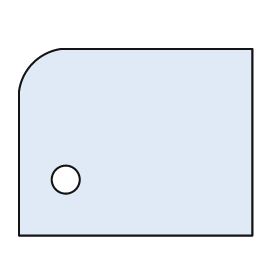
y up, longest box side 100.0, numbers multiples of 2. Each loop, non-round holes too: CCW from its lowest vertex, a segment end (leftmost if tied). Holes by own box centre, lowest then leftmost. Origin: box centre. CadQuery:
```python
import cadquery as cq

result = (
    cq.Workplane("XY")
    .moveTo(-50.0, -40.0)
    .lineTo(50.0, -40.0)
    .lineTo(50.0, 40.0)
    .lineTo(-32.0, 40.0)
    .threePointArc((-44.0, 34.0), (-50.0, 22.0))
    .close()
    .moveTo(-30.0, -16.0)
    .circle(6.0)
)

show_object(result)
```